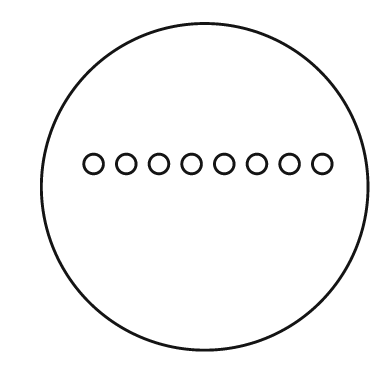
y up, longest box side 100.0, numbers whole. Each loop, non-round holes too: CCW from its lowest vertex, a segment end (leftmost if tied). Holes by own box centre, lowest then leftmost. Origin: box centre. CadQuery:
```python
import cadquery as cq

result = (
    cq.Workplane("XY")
    .moveTo(0.0, 0.0)
    .circle(50.0)
    .moveTo(-34.0, 7.0)
    .circle(3.0)
    .moveTo(-24.0, 7.0)
    .circle(3.0)
    .moveTo(-14.0, 7.0)
    .circle(3.0)
    .moveTo(-4.0, 7.0)
    .circle(3.0)
    .moveTo(6.0, 7.0)
    .circle(3.0)
    .moveTo(16.0, 7.0)
    .circle(3.0)
    .moveTo(26.0, 7.0)
    .circle(3.0)
    .moveTo(36.0, 7.0)
    .circle(3.0)
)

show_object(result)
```